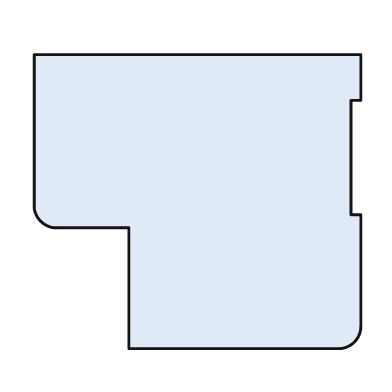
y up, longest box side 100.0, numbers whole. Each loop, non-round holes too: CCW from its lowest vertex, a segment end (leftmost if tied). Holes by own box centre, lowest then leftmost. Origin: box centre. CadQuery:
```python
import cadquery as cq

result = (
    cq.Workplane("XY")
    .moveTo(-21.0, -45.0)
    .lineTo(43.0, -45.0)
    .threePointArc((48.0, -43.0), (50.0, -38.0))
    .lineTo(50.0, -4.0)
    .lineTo(47.0, -4.0)
    .lineTo(47.0, 31.0)
    .lineTo(50.0, 31.0)
    .lineTo(50.0, 45.0)
    .lineTo(-50.0, 45.0)
    .lineTo(-50.0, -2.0)
    .threePointArc((-48.0, -6.0), (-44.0, -8.0))
    .lineTo(-21.0, -8.0)
    .close()
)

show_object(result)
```